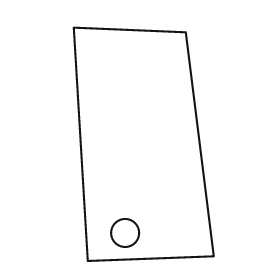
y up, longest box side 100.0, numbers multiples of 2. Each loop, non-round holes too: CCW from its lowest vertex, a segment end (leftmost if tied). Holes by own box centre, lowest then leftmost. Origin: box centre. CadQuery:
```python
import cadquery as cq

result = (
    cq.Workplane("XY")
    .moveTo(-24.0, -50.0)
    .lineTo(30.0, -48.0)
    .lineTo(18.0, 48.0)
    .lineTo(-30.0, 50.0)
    .close()
    .moveTo(-8.0, -38.0)
    .circle(6.0)
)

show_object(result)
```